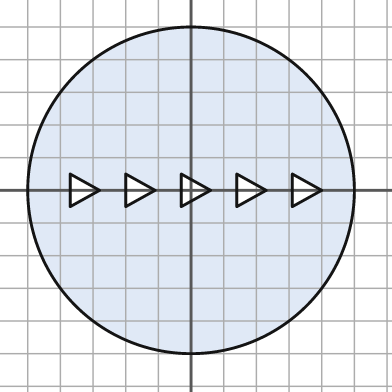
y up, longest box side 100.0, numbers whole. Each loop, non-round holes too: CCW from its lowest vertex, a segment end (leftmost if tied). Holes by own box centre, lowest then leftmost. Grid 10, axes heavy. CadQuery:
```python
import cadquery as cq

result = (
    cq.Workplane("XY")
    .moveTo(0.0, 0.0)
    .circle(50.0)
    .moveTo(-37.0, -5.0)
    .lineTo(-28.0, 0.0)
    .lineTo(-37.0, 5.0)
    .close()
    .moveTo(-20.0, -5.0)
    .lineTo(-11.0, 0.0)
    .lineTo(-20.0, 5.0)
    .close()
    .moveTo(-3.0, -5.0)
    .lineTo(6.0, 0.0)
    .lineTo(-3.0, 5.0)
    .close()
    .moveTo(14.0, -5.0)
    .lineTo(23.0, 0.0)
    .lineTo(14.0, 5.0)
    .close()
    .moveTo(31.0, -5.0)
    .lineTo(40.0, 0.0)
    .lineTo(31.0, 5.0)
    .close()
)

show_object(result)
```